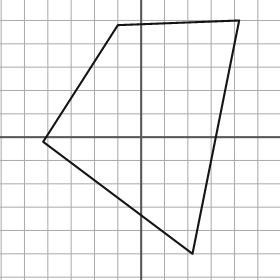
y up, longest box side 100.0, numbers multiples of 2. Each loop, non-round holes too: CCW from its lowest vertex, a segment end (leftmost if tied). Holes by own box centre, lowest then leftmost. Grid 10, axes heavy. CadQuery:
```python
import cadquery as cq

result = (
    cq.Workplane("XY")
    .moveTo(22.0, -50.0)
    .lineTo(42.0, 50.0)
    .lineTo(-10.0, 48.0)
    .lineTo(-42.0, -2.0)
    .close()
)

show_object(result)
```